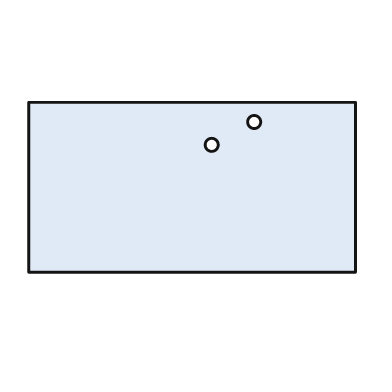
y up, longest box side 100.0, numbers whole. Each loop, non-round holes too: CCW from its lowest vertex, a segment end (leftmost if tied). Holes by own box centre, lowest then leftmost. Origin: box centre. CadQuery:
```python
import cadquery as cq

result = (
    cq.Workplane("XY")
    .moveTo(-50.0, -26.0)
    .lineTo(50.0, -26.0)
    .lineTo(50.0, 26.0)
    .lineTo(-50.0, 26.0)
    .close()
    .moveTo(6.0, 13.0)
    .circle(2.0)
    .moveTo(19.0, 20.0)
    .circle(2.0)
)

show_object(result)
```